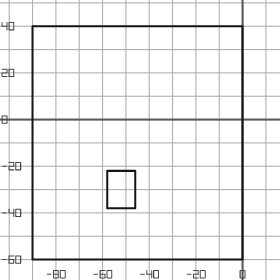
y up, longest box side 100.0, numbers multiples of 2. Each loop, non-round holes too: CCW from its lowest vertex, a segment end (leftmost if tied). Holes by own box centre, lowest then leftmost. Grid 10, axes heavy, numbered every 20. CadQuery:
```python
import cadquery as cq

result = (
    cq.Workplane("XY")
    .moveTo(-90.0, -60.0)
    .lineTo(0.0, -60.0)
    .lineTo(0.0, 40.0)
    .lineTo(-90.0, 40.0)
    .close()
    .moveTo(-58.0, -38.0)
    .lineTo(-46.0, -38.0)
    .lineTo(-46.0, -22.0)
    .lineTo(-58.0, -22.0)
    .close()
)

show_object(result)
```